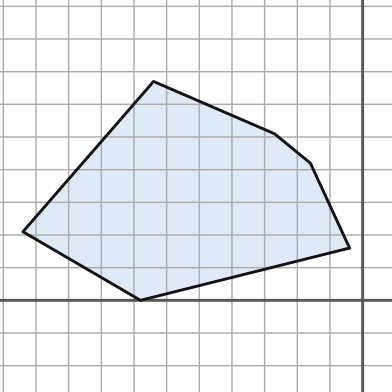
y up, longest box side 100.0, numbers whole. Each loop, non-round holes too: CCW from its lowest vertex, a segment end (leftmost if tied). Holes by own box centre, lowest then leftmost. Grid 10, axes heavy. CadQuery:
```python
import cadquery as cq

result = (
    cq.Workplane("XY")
    .moveTo(-68.0, 0.0)
    .lineTo(-4.0, 16.0)
    .lineTo(-16.0, 42.0)
    .lineTo(-27.0, 51.0)
    .lineTo(-64.0, 67.0)
    .lineTo(-104.0, 21.0)
    .close()
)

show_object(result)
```